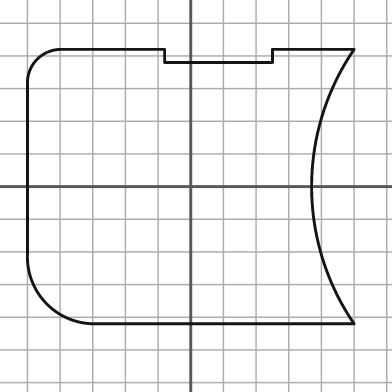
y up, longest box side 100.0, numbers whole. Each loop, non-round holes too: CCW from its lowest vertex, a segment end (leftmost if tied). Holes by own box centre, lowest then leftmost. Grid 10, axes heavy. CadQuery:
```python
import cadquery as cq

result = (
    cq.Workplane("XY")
    .moveTo(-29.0, -42.0)
    .lineTo(50.0, -42.0)
    .threePointArc((37.0, 0.0), (50.0, 42.0))
    .lineTo(25.0, 42.0)
    .lineTo(25.0, 38.0)
    .lineTo(-8.0, 38.0)
    .lineTo(-8.0, 42.0)
    .lineTo(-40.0, 42.0)
    .threePointArc((-47.0, 39.0), (-50.0, 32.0))
    .lineTo(-50.0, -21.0)
    .threePointArc((-44.0, -36.0), (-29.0, -42.0))
    .close()
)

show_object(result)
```